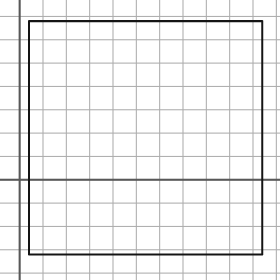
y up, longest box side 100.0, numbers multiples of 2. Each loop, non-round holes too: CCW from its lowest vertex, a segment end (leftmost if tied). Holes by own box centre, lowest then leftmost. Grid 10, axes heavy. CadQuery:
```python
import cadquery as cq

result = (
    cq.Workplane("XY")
    .moveTo(4.0, -32.0)
    .lineTo(104.0, -32.0)
    .lineTo(104.0, 68.0)
    .lineTo(4.0, 68.0)
    .close()
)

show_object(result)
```